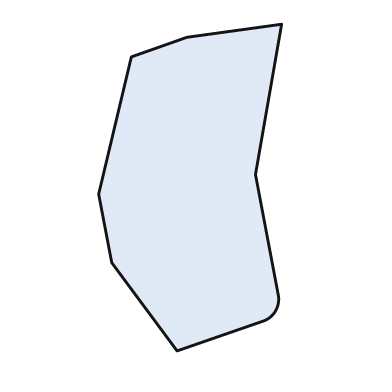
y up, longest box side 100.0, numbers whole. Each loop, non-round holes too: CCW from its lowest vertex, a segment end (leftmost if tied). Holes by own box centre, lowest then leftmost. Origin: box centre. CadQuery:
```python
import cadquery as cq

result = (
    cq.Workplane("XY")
    .moveTo(-4.0, -50.0)
    .lineTo(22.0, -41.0)
    .threePointArc((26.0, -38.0), (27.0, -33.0))
    .lineTo(20.0, 4.0)
    .lineTo(28.0, 50.0)
    .lineTo(-1.0, 46.0)
    .lineTo(-18.0, 40.0)
    .lineTo(-28.0, -2.0)
    .lineTo(-24.0, -23.0)
    .close()
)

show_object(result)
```